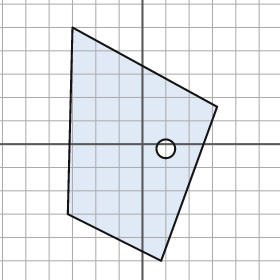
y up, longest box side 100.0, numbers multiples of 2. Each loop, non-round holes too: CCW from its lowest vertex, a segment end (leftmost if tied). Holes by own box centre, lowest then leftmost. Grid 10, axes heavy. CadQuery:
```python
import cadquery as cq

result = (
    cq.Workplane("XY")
    .moveTo(8.0, -50.0)
    .lineTo(32.0, 16.0)
    .lineTo(-30.0, 50.0)
    .lineTo(-32.0, -30.0)
    .close()
    .moveTo(10.0, -2.0)
    .circle(4.0)
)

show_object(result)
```